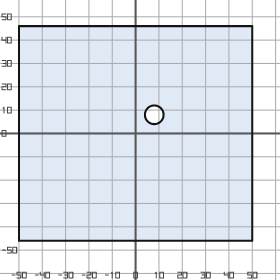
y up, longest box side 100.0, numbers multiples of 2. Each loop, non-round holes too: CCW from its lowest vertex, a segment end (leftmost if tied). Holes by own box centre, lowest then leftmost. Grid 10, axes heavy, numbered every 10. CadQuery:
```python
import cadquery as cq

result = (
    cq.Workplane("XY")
    .moveTo(-50.0, -46.0)
    .lineTo(50.0, -46.0)
    .lineTo(50.0, 46.0)
    .lineTo(-50.0, 46.0)
    .close()
    .moveTo(8.0, 8.0)
    .circle(4.0)
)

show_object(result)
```